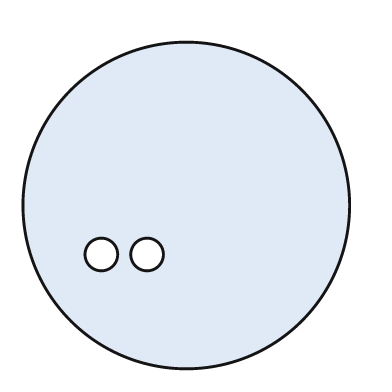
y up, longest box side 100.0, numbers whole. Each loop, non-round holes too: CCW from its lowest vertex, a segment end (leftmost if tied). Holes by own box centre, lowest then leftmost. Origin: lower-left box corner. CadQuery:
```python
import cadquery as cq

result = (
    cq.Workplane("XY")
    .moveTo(50.0, 50.0)
    .circle(50.0)
    .moveTo(24.0, 35.0)
    .circle(5.0)
    .moveTo(38.0, 35.0)
    .circle(5.0)
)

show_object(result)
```